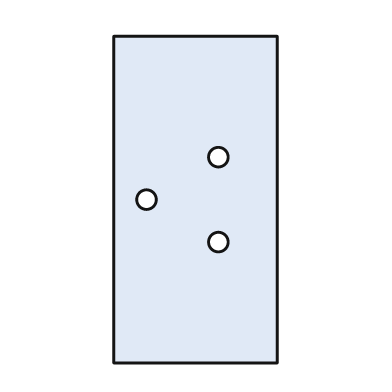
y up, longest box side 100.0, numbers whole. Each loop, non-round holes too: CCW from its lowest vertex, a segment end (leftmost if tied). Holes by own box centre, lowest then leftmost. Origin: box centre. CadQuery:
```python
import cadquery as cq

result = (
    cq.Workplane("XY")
    .moveTo(-25.0, -50.0)
    .lineTo(25.0, -50.0)
    .lineTo(25.0, 50.0)
    .lineTo(-25.0, 50.0)
    .close()
    .moveTo(7.0, -13.0)
    .circle(3.0)
    .moveTo(-15.0, 0.0)
    .circle(3.0)
    .moveTo(7.0, 13.0)
    .circle(3.0)
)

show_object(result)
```